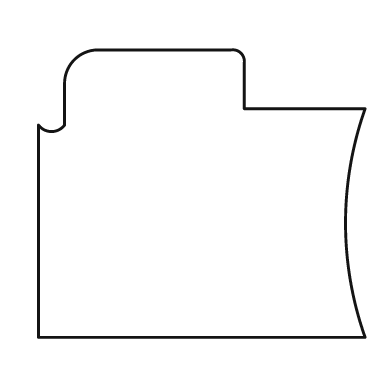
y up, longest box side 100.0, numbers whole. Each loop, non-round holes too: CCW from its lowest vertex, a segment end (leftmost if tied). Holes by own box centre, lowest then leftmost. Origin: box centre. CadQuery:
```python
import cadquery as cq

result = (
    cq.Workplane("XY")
    .moveTo(-50.0, -44.0)
    .lineTo(50.0, -44.0)
    .threePointArc((44.0, -9.0), (50.0, 26.0))
    .lineTo(13.0, 26.0)
    .lineTo(13.0, 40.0)
    .threePointArc((12.0, 43.0), (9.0, 44.0))
    .lineTo(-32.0, 44.0)
    .threePointArc((-39.0, 41.0), (-42.0, 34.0))
    .lineTo(-42.0, 21.0)
    .threePointArc((-46.0, 19.0), (-50.0, 21.0))
    .close()
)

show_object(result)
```